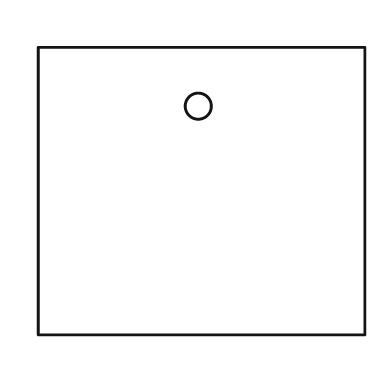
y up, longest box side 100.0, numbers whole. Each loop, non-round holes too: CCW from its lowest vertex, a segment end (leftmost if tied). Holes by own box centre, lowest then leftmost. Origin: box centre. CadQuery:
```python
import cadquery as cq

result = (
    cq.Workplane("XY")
    .moveTo(-50.0, -44.0)
    .lineTo(50.0, -44.0)
    .lineTo(50.0, 44.0)
    .lineTo(-50.0, 44.0)
    .close()
    .moveTo(-1.0, 26.0)
    .circle(4.0)
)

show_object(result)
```